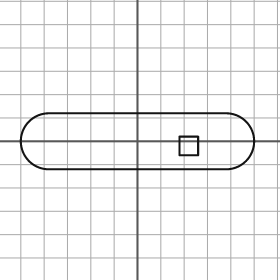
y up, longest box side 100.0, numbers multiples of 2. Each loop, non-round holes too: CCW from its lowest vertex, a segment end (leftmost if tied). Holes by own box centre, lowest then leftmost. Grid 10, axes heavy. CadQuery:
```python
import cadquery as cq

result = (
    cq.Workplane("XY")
    .moveTo(-38.0, -12.0)
    .lineTo(38.0, -12.0)
    .threePointArc((50.0, 0.0), (38.0, 12.0))
    .lineTo(-38.0, 12.0)
    .threePointArc((-50.0, 0.0), (-38.0, -12.0))
    .close()
    .moveTo(18.0, -6.0)
    .lineTo(26.0, -6.0)
    .lineTo(26.0, 2.0)
    .lineTo(18.0, 2.0)
    .close()
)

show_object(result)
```